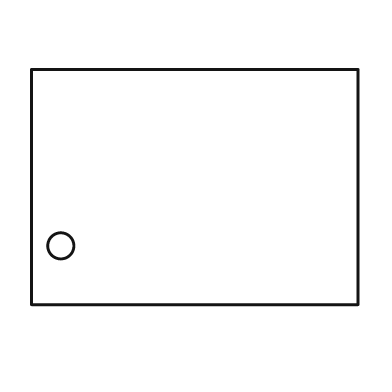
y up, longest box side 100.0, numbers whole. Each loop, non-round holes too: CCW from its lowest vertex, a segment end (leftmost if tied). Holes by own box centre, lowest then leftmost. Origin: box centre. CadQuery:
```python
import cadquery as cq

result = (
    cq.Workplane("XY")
    .moveTo(-50.0, -36.0)
    .lineTo(50.0, -36.0)
    .lineTo(50.0, 36.0)
    .lineTo(-50.0, 36.0)
    .close()
    .moveTo(-41.0, -18.0)
    .circle(4.0)
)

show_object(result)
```